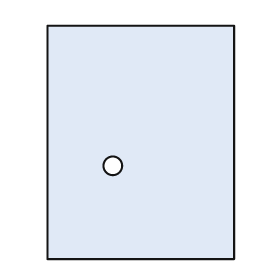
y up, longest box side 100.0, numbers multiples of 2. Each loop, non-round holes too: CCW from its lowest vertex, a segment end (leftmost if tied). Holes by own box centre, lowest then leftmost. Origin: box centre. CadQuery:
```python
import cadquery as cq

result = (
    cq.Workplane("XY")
    .moveTo(-40.0, -50.0)
    .lineTo(40.0, -50.0)
    .lineTo(40.0, 50.0)
    .lineTo(-40.0, 50.0)
    .close()
    .moveTo(-12.0, -10.0)
    .circle(4.0)
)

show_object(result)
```